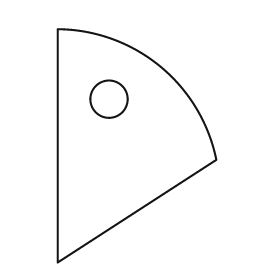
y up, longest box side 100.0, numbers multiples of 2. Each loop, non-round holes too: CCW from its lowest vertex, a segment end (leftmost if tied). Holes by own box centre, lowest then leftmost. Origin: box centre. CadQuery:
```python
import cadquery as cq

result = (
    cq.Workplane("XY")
    .moveTo(-34.0, -50.0)
    .lineTo(34.0, -6.0)
    .threePointArc((10.0, 34.0), (-34.0, 50.0))
    .close()
    .moveTo(-12.0, 20.0)
    .circle(8.0)
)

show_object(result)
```